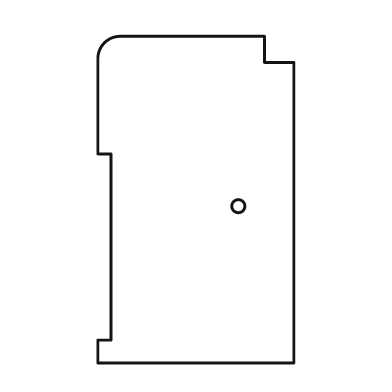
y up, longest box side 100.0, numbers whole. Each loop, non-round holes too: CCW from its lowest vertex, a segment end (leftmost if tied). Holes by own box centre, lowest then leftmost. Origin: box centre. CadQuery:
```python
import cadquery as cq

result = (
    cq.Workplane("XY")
    .moveTo(-30.0, -50.0)
    .lineTo(30.0, -50.0)
    .lineTo(30.0, 42.0)
    .lineTo(21.0, 42.0)
    .lineTo(21.0, 50.0)
    .lineTo(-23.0, 50.0)
    .threePointArc((-28.0, 48.0), (-30.0, 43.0))
    .lineTo(-30.0, 14.0)
    .lineTo(-26.0, 14.0)
    .lineTo(-26.0, -43.0)
    .lineTo(-30.0, -43.0)
    .close()
    .moveTo(13.0, -2.0)
    .circle(2.0)
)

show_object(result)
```